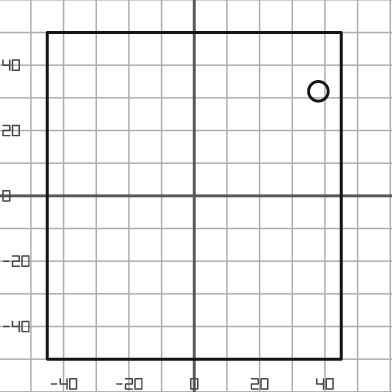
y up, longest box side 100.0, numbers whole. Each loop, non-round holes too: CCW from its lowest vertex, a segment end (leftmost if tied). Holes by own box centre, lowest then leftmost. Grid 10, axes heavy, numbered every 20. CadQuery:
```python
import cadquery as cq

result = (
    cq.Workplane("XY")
    .moveTo(-45.0, -50.0)
    .lineTo(45.0, -50.0)
    .lineTo(45.0, 50.0)
    .lineTo(-45.0, 50.0)
    .close()
    .moveTo(38.0, 32.0)
    .circle(3.0)
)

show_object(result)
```